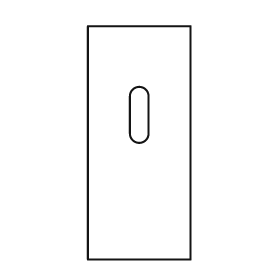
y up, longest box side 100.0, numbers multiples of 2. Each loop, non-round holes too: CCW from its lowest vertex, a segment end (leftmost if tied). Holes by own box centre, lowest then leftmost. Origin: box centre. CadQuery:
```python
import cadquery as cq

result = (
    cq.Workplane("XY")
    .moveTo(-22.0, -50.0)
    .lineTo(22.0, -50.0)
    .lineTo(22.0, 50.0)
    .lineTo(-22.0, 50.0)
    .close()
    .moveTo(-4.0, 4.0)
    .threePointArc((0.0, 0.0), (4.0, 4.0))
    .lineTo(4.0, 20.0)
    .threePointArc((0.0, 24.0), (-4.0, 20.0))
    .close()
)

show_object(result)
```